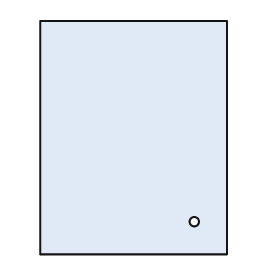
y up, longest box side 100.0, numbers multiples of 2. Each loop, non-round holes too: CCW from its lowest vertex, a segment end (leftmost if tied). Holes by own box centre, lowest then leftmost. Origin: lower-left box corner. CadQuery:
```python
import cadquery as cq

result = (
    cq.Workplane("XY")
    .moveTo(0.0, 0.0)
    .lineTo(80.0, 0.0)
    .lineTo(80.0, 100.0)
    .lineTo(0.0, 100.0)
    .close()
    .moveTo(66.0, 14.0)
    .circle(2.0)
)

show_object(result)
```